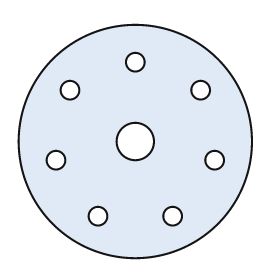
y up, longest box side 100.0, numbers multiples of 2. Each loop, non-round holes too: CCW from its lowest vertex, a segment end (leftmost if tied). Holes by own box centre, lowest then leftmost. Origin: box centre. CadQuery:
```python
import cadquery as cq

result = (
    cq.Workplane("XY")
    .moveTo(0.0, 0.0)
    .circle(50.0)
    .moveTo(-16.0, -32.0)
    .circle(4.0)
    .moveTo(16.0, -32.0)
    .circle(4.0)
    .moveTo(-34.0, -8.0)
    .circle(4.0)
    .moveTo(34.0, -8.0)
    .circle(4.0)
    .moveTo(0.0, 0.0)
    .circle(8.0)
    .moveTo(-28.0, 22.0)
    .circle(4.0)
    .moveTo(28.0, 22.0)
    .circle(4.0)
    .moveTo(0.0, 34.0)
    .circle(4.0)
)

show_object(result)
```